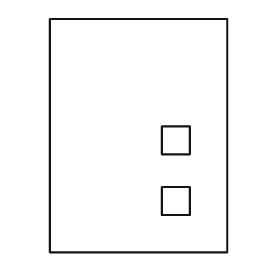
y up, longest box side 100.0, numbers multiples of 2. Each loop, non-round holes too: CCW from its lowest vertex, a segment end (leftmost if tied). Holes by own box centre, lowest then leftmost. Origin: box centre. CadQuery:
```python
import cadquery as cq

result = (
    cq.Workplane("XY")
    .moveTo(-38.0, -50.0)
    .lineTo(38.0, -50.0)
    .lineTo(38.0, 50.0)
    .lineTo(-38.0, 50.0)
    .close()
    .moveTo(10.0, -34.0)
    .lineTo(22.0, -34.0)
    .lineTo(22.0, -22.0)
    .lineTo(10.0, -22.0)
    .close()
    .moveTo(10.0, -8.0)
    .lineTo(22.0, -8.0)
    .lineTo(22.0, 4.0)
    .lineTo(10.0, 4.0)
    .close()
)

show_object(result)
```